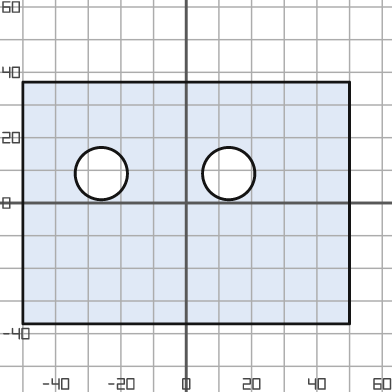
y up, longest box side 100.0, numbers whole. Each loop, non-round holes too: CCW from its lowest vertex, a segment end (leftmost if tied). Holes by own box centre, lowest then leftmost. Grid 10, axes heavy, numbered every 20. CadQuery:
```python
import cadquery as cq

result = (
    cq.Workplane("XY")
    .moveTo(-50.0, -37.0)
    .lineTo(50.0, -37.0)
    .lineTo(50.0, 37.0)
    .lineTo(-50.0, 37.0)
    .close()
    .moveTo(-26.0, 9.0)
    .circle(8.0)
    .moveTo(13.0, 9.0)
    .circle(8.0)
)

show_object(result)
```